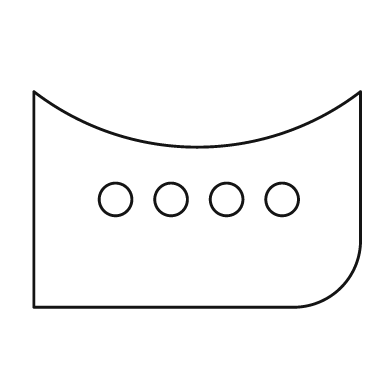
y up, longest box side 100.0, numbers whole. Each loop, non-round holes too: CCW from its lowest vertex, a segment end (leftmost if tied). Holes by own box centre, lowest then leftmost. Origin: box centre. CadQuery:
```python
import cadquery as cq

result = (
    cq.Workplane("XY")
    .moveTo(-50.0, -33.0)
    .lineTo(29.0, -33.0)
    .threePointArc((44.0, -27.0), (50.0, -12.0))
    .lineTo(50.0, 33.0)
    .threePointArc((0.0, 16.0), (-50.0, 33.0))
    .close()
    .moveTo(-25.0, 0.0)
    .circle(5.0)
    .moveTo(-8.0, 0.0)
    .circle(5.0)
    .moveTo(9.0, 0.0)
    .circle(5.0)
    .moveTo(26.0, 0.0)
    .circle(5.0)
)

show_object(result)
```